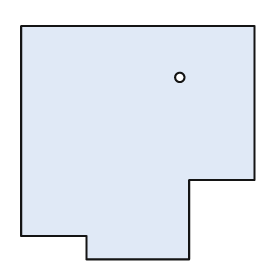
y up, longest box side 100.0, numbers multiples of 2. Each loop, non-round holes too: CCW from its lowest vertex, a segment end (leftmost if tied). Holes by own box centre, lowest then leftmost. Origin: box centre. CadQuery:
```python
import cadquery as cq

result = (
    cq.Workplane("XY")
    .moveTo(-22.0, -50.0)
    .lineTo(22.0, -50.0)
    .lineTo(22.0, -16.0)
    .lineTo(50.0, -16.0)
    .lineTo(50.0, 50.0)
    .lineTo(-50.0, 50.0)
    .lineTo(-50.0, -40.0)
    .lineTo(-22.0, -40.0)
    .close()
    .moveTo(18.0, 28.0)
    .circle(2.0)
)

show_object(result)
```